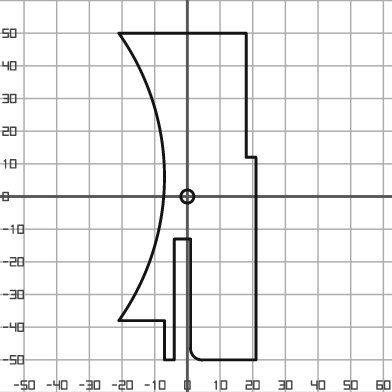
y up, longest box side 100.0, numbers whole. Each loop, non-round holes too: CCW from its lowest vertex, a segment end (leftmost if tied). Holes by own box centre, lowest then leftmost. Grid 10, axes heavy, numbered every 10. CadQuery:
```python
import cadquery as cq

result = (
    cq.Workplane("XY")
    .moveTo(-7.0, -50.0)
    .lineTo(-4.0, -50.0)
    .lineTo(-4.0, -13.0)
    .lineTo(1.0, -13.0)
    .lineTo(1.0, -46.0)
    .threePointArc((2.0, -49.0), (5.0, -50.0))
    .lineTo(21.0, -50.0)
    .lineTo(21.0, 12.0)
    .lineTo(18.0, 12.0)
    .lineTo(18.0, 50.0)
    .lineTo(-21.0, 50.0)
    .threePointArc((-7.0, 6.0), (-21.0, -38.0))
    .lineTo(-7.0, -38.0)
    .close()
    .moveTo(0.0, 0.0)
    .circle(2.0)
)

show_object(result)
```